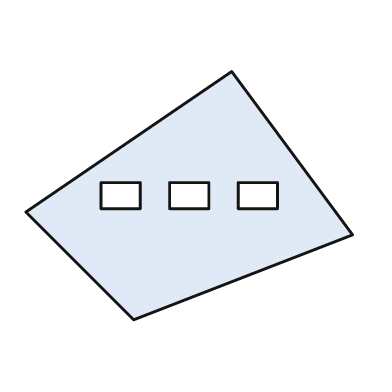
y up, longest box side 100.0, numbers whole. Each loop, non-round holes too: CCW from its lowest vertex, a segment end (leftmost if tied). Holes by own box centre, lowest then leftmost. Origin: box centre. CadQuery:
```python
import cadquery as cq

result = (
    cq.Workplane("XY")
    .moveTo(-17.0, -38.0)
    .lineTo(50.0, -12.0)
    .lineTo(13.0, 38.0)
    .lineTo(-50.0, -5.0)
    .close()
    .moveTo(-27.0, -4.0)
    .lineTo(-15.0, -4.0)
    .lineTo(-15.0, 4.0)
    .lineTo(-27.0, 4.0)
    .close()
    .moveTo(-6.0, -4.0)
    .lineTo(6.0, -4.0)
    .lineTo(6.0, 4.0)
    .lineTo(-6.0, 4.0)
    .close()
    .moveTo(15.0, -4.0)
    .lineTo(27.0, -4.0)
    .lineTo(27.0, 4.0)
    .lineTo(15.0, 4.0)
    .close()
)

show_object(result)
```